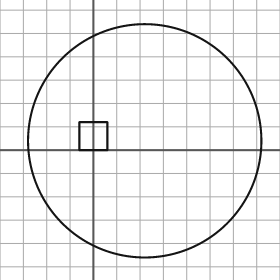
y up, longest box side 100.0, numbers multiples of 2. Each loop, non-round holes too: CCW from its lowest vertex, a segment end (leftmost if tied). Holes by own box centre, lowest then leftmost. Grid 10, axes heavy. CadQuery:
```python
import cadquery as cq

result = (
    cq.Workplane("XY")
    .moveTo(22.0, 4.0)
    .circle(50.0)
    .moveTo(-6.0, 0.0)
    .lineTo(6.0, 0.0)
    .lineTo(6.0, 12.0)
    .lineTo(-6.0, 12.0)
    .close()
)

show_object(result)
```